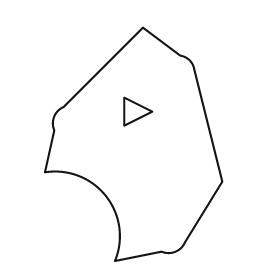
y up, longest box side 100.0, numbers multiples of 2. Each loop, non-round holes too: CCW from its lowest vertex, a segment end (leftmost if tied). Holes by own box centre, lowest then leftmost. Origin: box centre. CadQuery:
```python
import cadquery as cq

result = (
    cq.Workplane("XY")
    .moveTo(-8.0, -50.0)
    .lineTo(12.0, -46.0)
    .threePointArc((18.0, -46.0), (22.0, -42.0))
    .lineTo(38.0, -16.0)
    .lineTo(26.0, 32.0)
    .threePointArc((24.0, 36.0), (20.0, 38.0))
    .lineTo(4.0, 50.0)
    .lineTo(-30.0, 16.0)
    .threePointArc((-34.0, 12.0), (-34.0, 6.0))
    .lineTo(-38.0, -12.0)
    .threePointArc((-12.0, -22.0), (-8.0, -50.0))
    .close()
    .moveTo(-4.0, 8.0)
    .lineTo(8.0, 14.0)
    .lineTo(-4.0, 20.0)
    .close()
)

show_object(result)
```